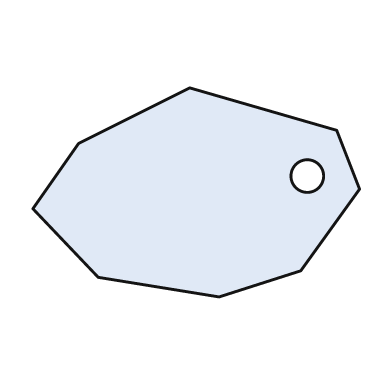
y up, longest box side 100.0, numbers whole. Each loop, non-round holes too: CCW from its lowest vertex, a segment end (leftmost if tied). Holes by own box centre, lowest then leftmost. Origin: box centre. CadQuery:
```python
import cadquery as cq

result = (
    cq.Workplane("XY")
    .moveTo(7.0, -32.0)
    .lineTo(32.0, -24.0)
    .lineTo(50.0, 1.0)
    .lineTo(43.0, 19.0)
    .lineTo(-2.0, 32.0)
    .lineTo(-36.0, 15.0)
    .lineTo(-50.0, -5.0)
    .lineTo(-30.0, -26.0)
    .close()
    .moveTo(34.0, 5.0)
    .circle(5.0)
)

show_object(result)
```